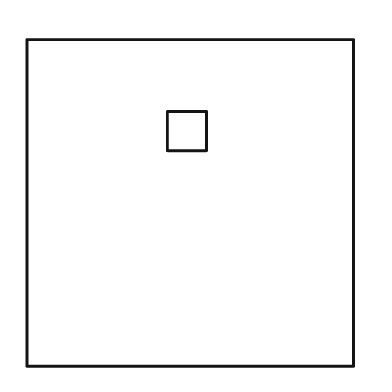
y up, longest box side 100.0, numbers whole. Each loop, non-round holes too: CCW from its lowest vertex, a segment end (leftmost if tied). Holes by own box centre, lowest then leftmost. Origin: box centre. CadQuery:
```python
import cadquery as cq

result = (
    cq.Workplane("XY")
    .moveTo(-50.0, -50.0)
    .lineTo(50.0, -50.0)
    .lineTo(50.0, 50.0)
    .lineTo(-50.0, 50.0)
    .close()
    .moveTo(-7.0, 16.0)
    .lineTo(5.0, 16.0)
    .lineTo(5.0, 28.0)
    .lineTo(-7.0, 28.0)
    .close()
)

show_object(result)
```